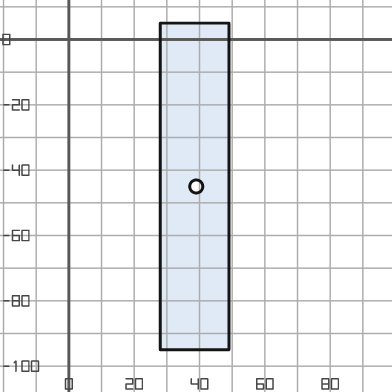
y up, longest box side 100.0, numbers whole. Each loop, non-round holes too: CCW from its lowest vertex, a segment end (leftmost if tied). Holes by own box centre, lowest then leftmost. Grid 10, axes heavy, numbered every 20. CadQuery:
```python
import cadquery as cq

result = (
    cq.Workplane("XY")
    .moveTo(28.0, -95.0)
    .lineTo(49.0, -95.0)
    .lineTo(49.0, 5.0)
    .lineTo(28.0, 5.0)
    .close()
    .moveTo(39.0, -45.0)
    .circle(2.0)
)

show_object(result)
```